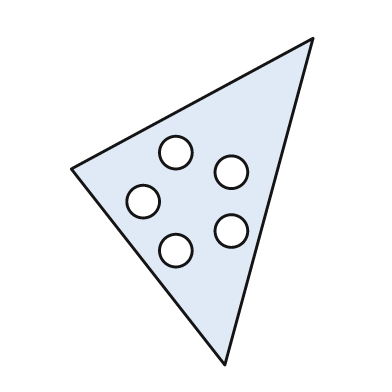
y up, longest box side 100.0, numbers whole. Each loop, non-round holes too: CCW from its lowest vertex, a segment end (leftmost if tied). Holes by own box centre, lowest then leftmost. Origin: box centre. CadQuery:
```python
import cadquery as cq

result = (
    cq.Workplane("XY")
    .moveTo(10.0, -50.0)
    .lineTo(37.0, 50.0)
    .lineTo(-37.0, 10.0)
    .close()
    .moveTo(-5.0, -15.0)
    .circle(5.0)
    .moveTo(12.0, -9.0)
    .circle(5.0)
    .moveTo(-15.0, 0.0)
    .circle(5.0)
    .moveTo(12.0, 9.0)
    .circle(5.0)
    .moveTo(-5.0, 15.0)
    .circle(5.0)
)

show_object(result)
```